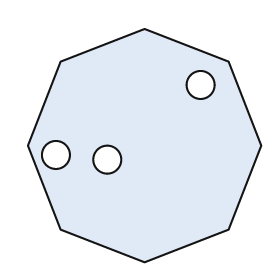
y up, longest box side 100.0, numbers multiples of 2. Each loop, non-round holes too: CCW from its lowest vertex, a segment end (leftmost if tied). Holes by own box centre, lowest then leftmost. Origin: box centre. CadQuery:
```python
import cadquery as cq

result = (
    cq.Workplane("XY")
    .moveTo(0.0, -50.0)
    .lineTo(36.0, -36.0)
    .lineTo(50.0, 0.0)
    .lineTo(36.0, 36.0)
    .lineTo(0.0, 50.0)
    .lineTo(-36.0, 36.0)
    .lineTo(-50.0, 0.0)
    .lineTo(-36.0, -36.0)
    .close()
    .moveTo(-16.0, -6.0)
    .circle(6.0)
    .moveTo(-38.0, -4.0)
    .circle(6.0)
    .moveTo(24.0, 26.0)
    .circle(6.0)
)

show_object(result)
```